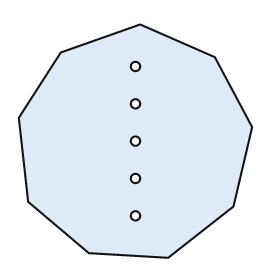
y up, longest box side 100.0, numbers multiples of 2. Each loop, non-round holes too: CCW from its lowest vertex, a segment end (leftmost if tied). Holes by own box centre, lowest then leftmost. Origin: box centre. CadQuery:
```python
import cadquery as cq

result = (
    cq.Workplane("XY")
    .moveTo(14.0, -50.0)
    .lineTo(42.0, -28.0)
    .lineTo(50.0, 6.0)
    .lineTo(34.0, 36.0)
    .lineTo(2.0, 50.0)
    .lineTo(-32.0, 38.0)
    .lineTo(-50.0, 10.0)
    .lineTo(-46.0, -26.0)
    .lineTo(-20.0, -48.0)
    .close()
    .moveTo(0.0, -32.0)
    .circle(2.0)
    .moveTo(0.0, -16.0)
    .circle(2.0)
    .moveTo(0.0, 0.0)
    .circle(2.0)
    .moveTo(0.0, 16.0)
    .circle(2.0)
    .moveTo(0.0, 32.0)
    .circle(2.0)
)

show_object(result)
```